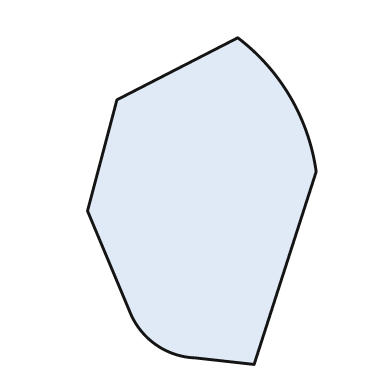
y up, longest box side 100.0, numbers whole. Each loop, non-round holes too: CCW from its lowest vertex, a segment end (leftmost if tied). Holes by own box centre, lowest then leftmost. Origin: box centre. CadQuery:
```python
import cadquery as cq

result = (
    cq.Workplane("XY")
    .moveTo(16.0, -50.0)
    .lineTo(35.0, 9.0)
    .threePointArc((27.0, 32.0), (11.0, 50.0))
    .lineTo(-26.0, 31.0)
    .lineTo(-35.0, -3.0)
    .lineTo(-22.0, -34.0)
    .threePointArc((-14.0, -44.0), (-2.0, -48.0))
    .close()
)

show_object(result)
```